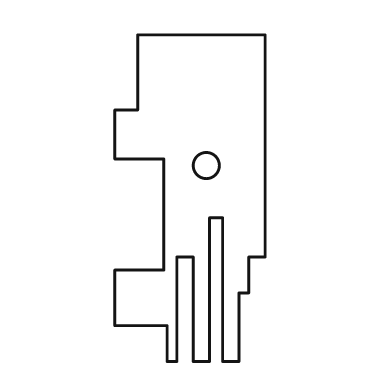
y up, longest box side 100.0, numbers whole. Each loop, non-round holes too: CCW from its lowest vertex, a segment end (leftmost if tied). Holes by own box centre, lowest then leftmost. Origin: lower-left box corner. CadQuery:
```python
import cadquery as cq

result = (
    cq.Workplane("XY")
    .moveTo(16.0, 0.0)
    .lineTo(19.0, 0.0)
    .lineTo(19.0, 32.0)
    .lineTo(24.0, 32.0)
    .lineTo(24.0, 0.0)
    .lineTo(29.0, 0.0)
    .lineTo(29.0, 44.0)
    .lineTo(33.0, 44.0)
    .lineTo(33.0, 0.0)
    .lineTo(38.0, 0.0)
    .lineTo(38.0, 21.0)
    .lineTo(41.0, 21.0)
    .lineTo(41.0, 32.0)
    .lineTo(46.0, 32.0)
    .lineTo(46.0, 100.0)
    .lineTo(7.0, 100.0)
    .lineTo(7.0, 77.0)
    .lineTo(0.0, 77.0)
    .lineTo(0.0, 62.0)
    .lineTo(15.0, 62.0)
    .lineTo(15.0, 28.0)
    .lineTo(0.0, 28.0)
    .lineTo(0.0, 11.0)
    .lineTo(16.0, 11.0)
    .close()
    .moveTo(28.0, 60.0)
    .circle(4.0)
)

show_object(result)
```